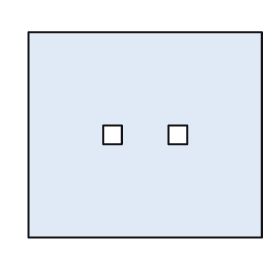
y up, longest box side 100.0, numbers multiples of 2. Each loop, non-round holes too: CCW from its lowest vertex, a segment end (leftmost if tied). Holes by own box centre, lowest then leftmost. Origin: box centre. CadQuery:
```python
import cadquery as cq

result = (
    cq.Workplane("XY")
    .moveTo(-50.0, -44.0)
    .lineTo(50.0, -44.0)
    .lineTo(50.0, 44.0)
    .lineTo(-50.0, 44.0)
    .close()
    .moveTo(-18.0, -4.0)
    .lineTo(-10.0, -4.0)
    .lineTo(-10.0, 4.0)
    .lineTo(-18.0, 4.0)
    .close()
    .moveTo(10.0, -4.0)
    .lineTo(18.0, -4.0)
    .lineTo(18.0, 4.0)
    .lineTo(10.0, 4.0)
    .close()
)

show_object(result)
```